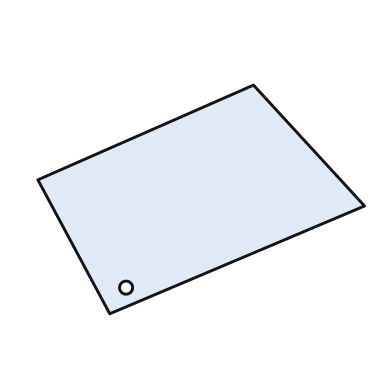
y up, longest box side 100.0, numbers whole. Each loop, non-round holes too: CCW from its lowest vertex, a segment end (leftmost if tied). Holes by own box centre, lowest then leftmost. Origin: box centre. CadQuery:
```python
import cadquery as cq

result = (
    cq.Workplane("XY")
    .moveTo(-28.0, -35.0)
    .lineTo(50.0, -2.0)
    .lineTo(16.0, 35.0)
    .lineTo(-50.0, 6.0)
    .close()
    .moveTo(-23.0, -27.0)
    .circle(2.0)
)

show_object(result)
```